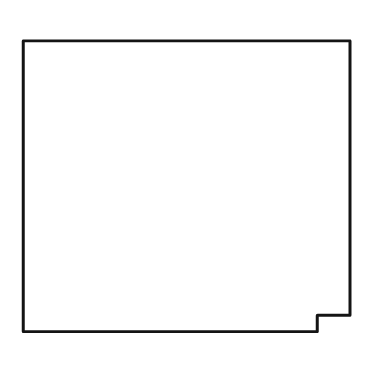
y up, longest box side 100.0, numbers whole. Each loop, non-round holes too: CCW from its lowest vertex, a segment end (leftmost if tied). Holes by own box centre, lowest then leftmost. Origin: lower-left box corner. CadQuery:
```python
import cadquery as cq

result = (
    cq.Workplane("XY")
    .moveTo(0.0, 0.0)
    .lineTo(90.0, 0.0)
    .lineTo(90.0, 5.0)
    .lineTo(100.0, 5.0)
    .lineTo(100.0, 89.0)
    .lineTo(0.0, 89.0)
    .close()
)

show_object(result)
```